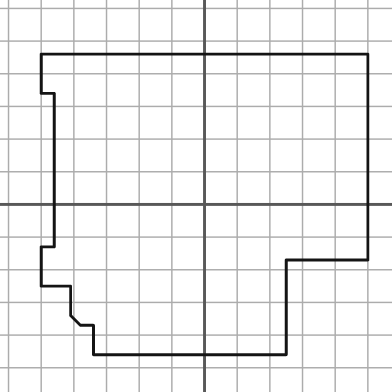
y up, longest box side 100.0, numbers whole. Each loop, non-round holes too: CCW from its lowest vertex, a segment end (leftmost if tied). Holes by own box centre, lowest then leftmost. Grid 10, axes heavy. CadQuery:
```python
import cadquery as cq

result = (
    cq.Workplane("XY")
    .moveTo(-34.0, -46.0)
    .lineTo(25.0, -46.0)
    .lineTo(25.0, -17.0)
    .lineTo(50.0, -17.0)
    .lineTo(50.0, 46.0)
    .lineTo(-50.0, 46.0)
    .lineTo(-50.0, 34.0)
    .lineTo(-46.0, 34.0)
    .lineTo(-46.0, -13.0)
    .lineTo(-50.0, -13.0)
    .lineTo(-50.0, -25.0)
    .lineTo(-41.0, -25.0)
    .lineTo(-41.0, -34.0)
    .lineTo(-38.0, -37.0)
    .lineTo(-34.0, -37.0)
    .close()
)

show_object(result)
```